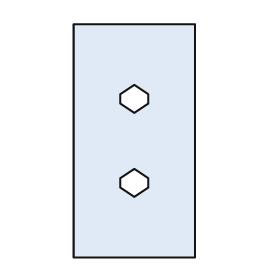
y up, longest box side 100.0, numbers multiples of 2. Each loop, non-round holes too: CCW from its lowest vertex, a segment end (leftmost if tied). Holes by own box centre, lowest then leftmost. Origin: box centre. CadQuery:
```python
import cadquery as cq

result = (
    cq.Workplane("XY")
    .moveTo(-26.0, -50.0)
    .lineTo(26.0, -50.0)
    .lineTo(26.0, 50.0)
    .lineTo(-26.0, 50.0)
    .close()
    .moveTo(0.0, -24.0)
    .lineTo(6.0, -20.0)
    .lineTo(6.0, -16.0)
    .lineTo(0.0, -12.0)
    .lineTo(-6.0, -16.0)
    .lineTo(-6.0, -20.0)
    .close()
    .moveTo(0.0, 12.0)
    .lineTo(6.0, 16.0)
    .lineTo(6.0, 20.0)
    .lineTo(0.0, 24.0)
    .lineTo(-6.0, 20.0)
    .lineTo(-6.0, 16.0)
    .close()
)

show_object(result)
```